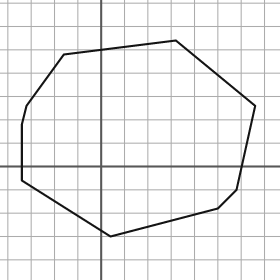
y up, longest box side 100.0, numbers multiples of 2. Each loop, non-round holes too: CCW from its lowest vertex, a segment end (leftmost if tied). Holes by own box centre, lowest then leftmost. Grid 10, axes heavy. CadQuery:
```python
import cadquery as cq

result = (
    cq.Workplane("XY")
    .moveTo(4.0, -30.0)
    .lineTo(50.0, -18.0)
    .lineTo(58.0, -10.0)
    .lineTo(66.0, 26.0)
    .lineTo(32.0, 54.0)
    .lineTo(-16.0, 48.0)
    .lineTo(-32.0, 26.0)
    .lineTo(-34.0, 18.0)
    .lineTo(-34.0, -6.0)
    .close()
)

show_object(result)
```